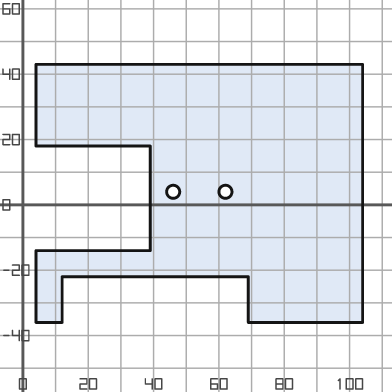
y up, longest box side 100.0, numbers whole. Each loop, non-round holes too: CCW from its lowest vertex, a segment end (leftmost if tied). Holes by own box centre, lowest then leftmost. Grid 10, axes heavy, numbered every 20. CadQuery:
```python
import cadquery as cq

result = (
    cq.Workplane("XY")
    .moveTo(4.0, -36.0)
    .lineTo(12.0, -36.0)
    .lineTo(12.0, -22.0)
    .lineTo(69.0, -22.0)
    .lineTo(69.0, -36.0)
    .lineTo(104.0, -36.0)
    .lineTo(104.0, 43.0)
    .lineTo(4.0, 43.0)
    .lineTo(4.0, 18.0)
    .lineTo(39.0, 18.0)
    .lineTo(39.0, -14.0)
    .lineTo(4.0, -14.0)
    .close()
    .moveTo(46.0, 4.0)
    .circle(2.0)
    .moveTo(62.0, 4.0)
    .circle(2.0)
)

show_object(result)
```